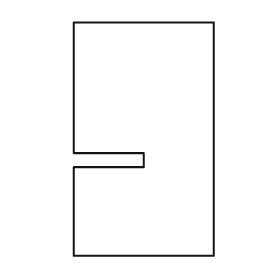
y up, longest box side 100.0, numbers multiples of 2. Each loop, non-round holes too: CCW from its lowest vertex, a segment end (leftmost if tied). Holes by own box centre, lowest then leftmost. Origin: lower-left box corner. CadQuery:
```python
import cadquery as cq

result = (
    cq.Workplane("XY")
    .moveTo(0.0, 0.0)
    .lineTo(60.0, 0.0)
    .lineTo(60.0, 100.0)
    .lineTo(0.0, 100.0)
    .lineTo(0.0, 44.0)
    .lineTo(30.0, 44.0)
    .lineTo(30.0, 38.0)
    .lineTo(0.0, 38.0)
    .close()
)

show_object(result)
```